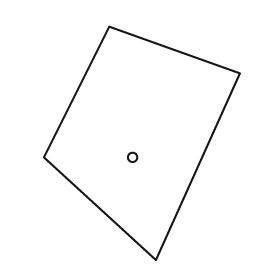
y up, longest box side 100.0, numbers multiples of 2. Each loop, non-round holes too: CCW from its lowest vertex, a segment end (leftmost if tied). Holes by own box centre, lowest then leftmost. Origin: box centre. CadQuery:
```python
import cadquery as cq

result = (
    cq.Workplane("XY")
    .moveTo(6.0, -50.0)
    .lineTo(42.0, 30.0)
    .lineTo(-14.0, 50.0)
    .lineTo(-42.0, -6.0)
    .close()
    .moveTo(-4.0, -6.0)
    .circle(2.0)
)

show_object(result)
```